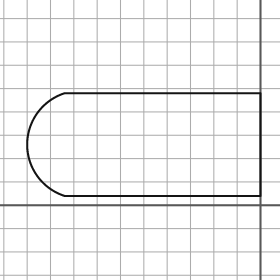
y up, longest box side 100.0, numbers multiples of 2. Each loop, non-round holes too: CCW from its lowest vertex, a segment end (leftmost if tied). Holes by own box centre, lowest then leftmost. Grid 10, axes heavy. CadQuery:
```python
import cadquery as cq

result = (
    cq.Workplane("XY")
    .moveTo(-84.0, 4.0)
    .lineTo(0.0, 4.0)
    .lineTo(0.0, 48.0)
    .lineTo(-84.0, 48.0)
    .threePointArc((-100.0, 26.0), (-84.0, 4.0))
    .close()
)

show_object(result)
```